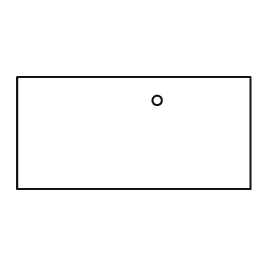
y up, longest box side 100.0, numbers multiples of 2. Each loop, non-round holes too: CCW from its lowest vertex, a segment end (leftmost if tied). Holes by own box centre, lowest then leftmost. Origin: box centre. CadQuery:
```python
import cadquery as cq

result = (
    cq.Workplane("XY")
    .moveTo(-50.0, -24.0)
    .lineTo(50.0, -24.0)
    .lineTo(50.0, 24.0)
    .lineTo(-50.0, 24.0)
    .close()
    .moveTo(10.0, 14.0)
    .circle(2.0)
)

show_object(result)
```